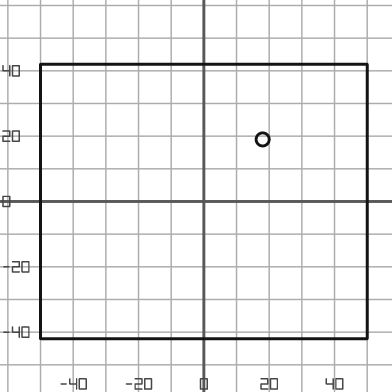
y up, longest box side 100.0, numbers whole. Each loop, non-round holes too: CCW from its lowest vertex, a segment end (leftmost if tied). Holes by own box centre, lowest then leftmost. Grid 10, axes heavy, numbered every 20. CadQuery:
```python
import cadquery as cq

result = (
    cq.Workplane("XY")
    .moveTo(-50.0, -42.0)
    .lineTo(50.0, -42.0)
    .lineTo(50.0, 42.0)
    .lineTo(-50.0, 42.0)
    .close()
    .moveTo(18.0, 19.0)
    .circle(2.0)
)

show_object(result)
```